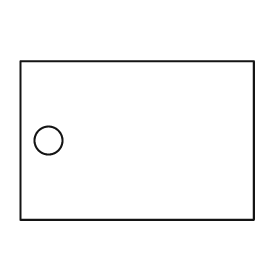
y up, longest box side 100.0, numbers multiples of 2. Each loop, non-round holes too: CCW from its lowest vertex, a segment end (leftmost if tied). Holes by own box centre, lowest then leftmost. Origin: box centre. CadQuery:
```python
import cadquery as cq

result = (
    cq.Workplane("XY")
    .moveTo(-50.0, -34.0)
    .lineTo(50.0, -34.0)
    .lineTo(50.0, 34.0)
    .lineTo(-50.0, 34.0)
    .close()
    .moveTo(-38.0, 0.0)
    .circle(6.0)
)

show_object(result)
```